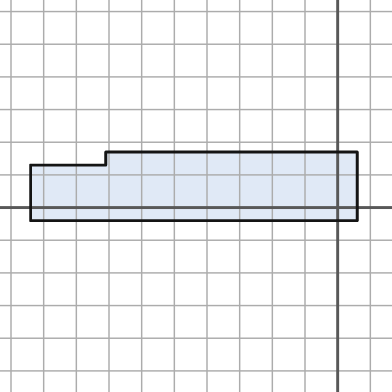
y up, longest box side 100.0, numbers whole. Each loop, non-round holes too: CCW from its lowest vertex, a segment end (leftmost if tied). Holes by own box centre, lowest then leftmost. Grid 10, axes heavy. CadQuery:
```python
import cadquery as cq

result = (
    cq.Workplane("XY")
    .moveTo(-94.0, -4.0)
    .lineTo(6.0, -4.0)
    .lineTo(6.0, 17.0)
    .lineTo(-71.0, 17.0)
    .lineTo(-71.0, 13.0)
    .lineTo(-94.0, 13.0)
    .close()
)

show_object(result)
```